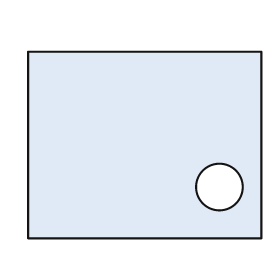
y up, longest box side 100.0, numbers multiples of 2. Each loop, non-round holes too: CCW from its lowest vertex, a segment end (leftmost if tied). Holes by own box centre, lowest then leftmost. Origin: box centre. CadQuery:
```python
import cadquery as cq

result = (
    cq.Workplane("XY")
    .moveTo(-50.0, -40.0)
    .lineTo(50.0, -40.0)
    .lineTo(50.0, 40.0)
    .lineTo(-50.0, 40.0)
    .close()
    .moveTo(32.0, -18.0)
    .circle(10.0)
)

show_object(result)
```